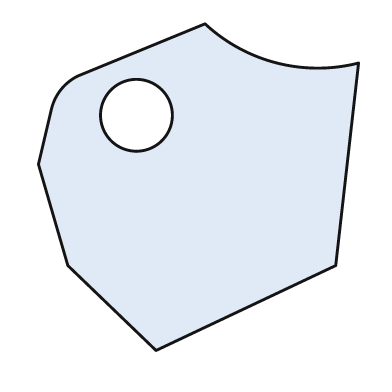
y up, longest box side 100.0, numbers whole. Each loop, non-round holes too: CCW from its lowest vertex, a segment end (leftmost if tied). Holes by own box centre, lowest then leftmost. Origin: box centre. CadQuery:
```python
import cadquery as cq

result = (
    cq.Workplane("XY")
    .moveTo(-13.0, -50.0)
    .lineTo(42.0, -24.0)
    .lineTo(49.0, 38.0)
    .threePointArc((24.0, 38.0), (2.0, 50.0))
    .lineTo(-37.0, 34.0)
    .threePointArc((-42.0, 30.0), (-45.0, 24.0))
    .lineTo(-49.0, 7.0)
    .lineTo(-40.0, -24.0)
    .close()
    .moveTo(-19.0, 22.0)
    .circle(11.0)
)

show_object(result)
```